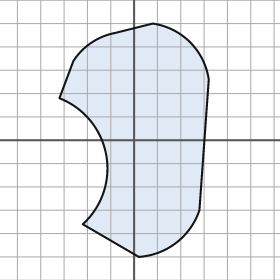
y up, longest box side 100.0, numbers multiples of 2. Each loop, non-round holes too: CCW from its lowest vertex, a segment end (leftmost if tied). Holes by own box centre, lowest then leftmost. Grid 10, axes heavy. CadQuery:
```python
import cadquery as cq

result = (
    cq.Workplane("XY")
    .moveTo(2.0, -50.0)
    .threePointArc((18.0, -44.0), (28.0, -30.0))
    .lineTo(32.0, 26.0)
    .threePointArc((24.0, 42.0), (8.0, 50.0))
    .lineTo(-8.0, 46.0)
    .threePointArc((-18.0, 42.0), (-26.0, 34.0))
    .lineTo(-32.0, 18.0)
    .threePointArc((-12.0, -6.0), (-22.0, -36.0))
    .close()
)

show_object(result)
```